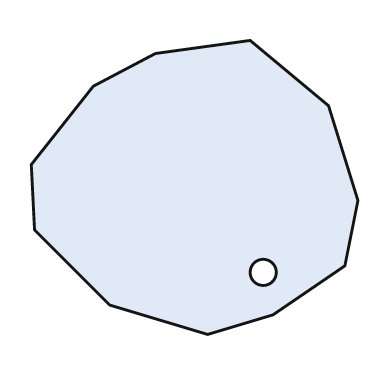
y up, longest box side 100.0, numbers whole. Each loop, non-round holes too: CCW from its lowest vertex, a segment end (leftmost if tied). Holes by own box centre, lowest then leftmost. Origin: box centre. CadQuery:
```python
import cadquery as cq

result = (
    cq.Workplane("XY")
    .moveTo(4.0, -45.0)
    .lineTo(24.0, -39.0)
    .lineTo(46.0, -24.0)
    .lineTo(50.0, -4.0)
    .lineTo(41.0, 25.0)
    .lineTo(17.0, 45.0)
    .lineTo(-12.0, 41.0)
    .lineTo(-31.0, 31.0)
    .lineTo(-50.0, 7.0)
    .lineTo(-49.0, -13.0)
    .lineTo(-26.0, -36.0)
    .close()
    .moveTo(21.0, -26.0)
    .circle(4.0)
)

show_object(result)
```